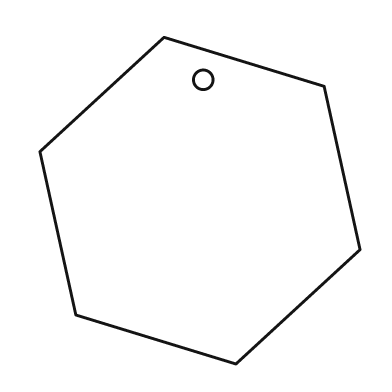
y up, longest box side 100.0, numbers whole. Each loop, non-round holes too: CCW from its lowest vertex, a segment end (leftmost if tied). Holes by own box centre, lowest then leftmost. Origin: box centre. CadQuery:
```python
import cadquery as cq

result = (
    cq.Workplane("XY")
    .moveTo(11.0, -50.0)
    .lineTo(49.0, -15.0)
    .lineTo(38.0, 35.0)
    .lineTo(-11.0, 50.0)
    .lineTo(-49.0, 15.0)
    .lineTo(-38.0, -35.0)
    .close()
    .moveTo(1.0, 37.0)
    .circle(3.0)
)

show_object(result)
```